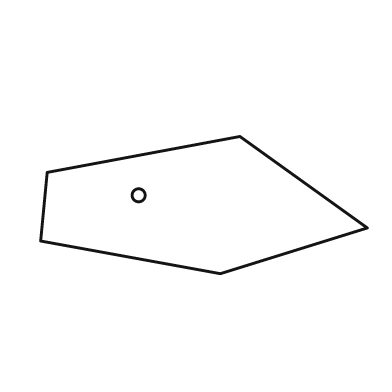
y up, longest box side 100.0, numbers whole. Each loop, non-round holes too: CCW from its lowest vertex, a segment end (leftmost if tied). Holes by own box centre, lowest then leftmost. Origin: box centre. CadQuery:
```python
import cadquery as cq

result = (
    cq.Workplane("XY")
    .moveTo(5.0, -21.0)
    .lineTo(50.0, -7.0)
    .lineTo(11.0, 21.0)
    .lineTo(-48.0, 10.0)
    .lineTo(-50.0, -11.0)
    .close()
    .moveTo(-20.0, 3.0)
    .circle(2.0)
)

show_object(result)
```